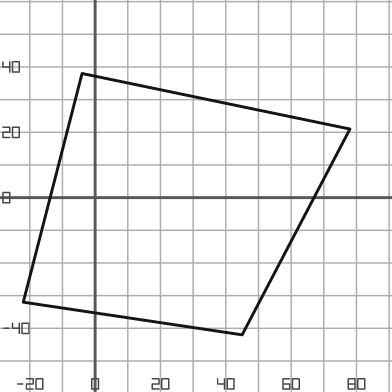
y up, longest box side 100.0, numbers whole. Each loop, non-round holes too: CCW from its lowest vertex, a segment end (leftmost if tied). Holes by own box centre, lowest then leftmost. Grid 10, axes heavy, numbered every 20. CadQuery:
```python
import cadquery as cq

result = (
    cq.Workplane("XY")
    .moveTo(45.0, -42.0)
    .lineTo(78.0, 21.0)
    .lineTo(-4.0, 38.0)
    .lineTo(-22.0, -32.0)
    .close()
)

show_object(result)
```